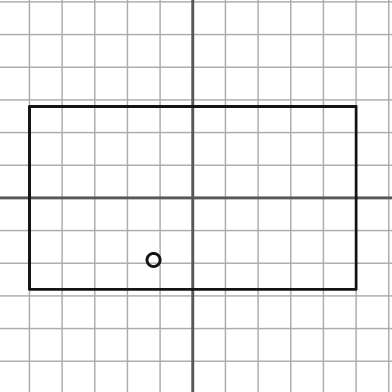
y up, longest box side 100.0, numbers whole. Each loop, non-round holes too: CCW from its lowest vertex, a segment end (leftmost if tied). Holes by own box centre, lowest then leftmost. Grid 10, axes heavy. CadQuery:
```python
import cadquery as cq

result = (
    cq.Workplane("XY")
    .moveTo(-50.0, -28.0)
    .lineTo(50.0, -28.0)
    .lineTo(50.0, 28.0)
    .lineTo(-50.0, 28.0)
    .close()
    .moveTo(-12.0, -19.0)
    .circle(2.0)
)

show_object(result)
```